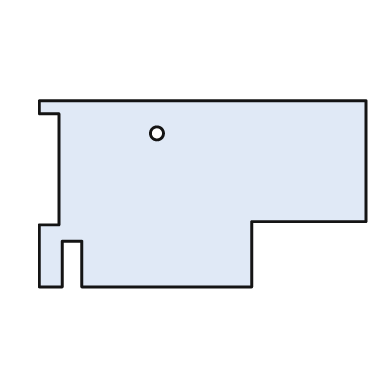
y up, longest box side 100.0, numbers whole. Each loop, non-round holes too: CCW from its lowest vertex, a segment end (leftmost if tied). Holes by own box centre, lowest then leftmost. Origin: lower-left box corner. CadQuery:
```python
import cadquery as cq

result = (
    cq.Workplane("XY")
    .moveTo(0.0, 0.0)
    .lineTo(7.0, 0.0)
    .lineTo(7.0, 14.0)
    .lineTo(13.0, 14.0)
    .lineTo(13.0, 0.0)
    .lineTo(65.0, 0.0)
    .lineTo(65.0, 20.0)
    .lineTo(100.0, 20.0)
    .lineTo(100.0, 57.0)
    .lineTo(0.0, 57.0)
    .lineTo(0.0, 53.0)
    .lineTo(6.0, 53.0)
    .lineTo(6.0, 19.0)
    .lineTo(0.0, 19.0)
    .close()
    .moveTo(36.0, 47.0)
    .circle(2.0)
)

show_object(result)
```